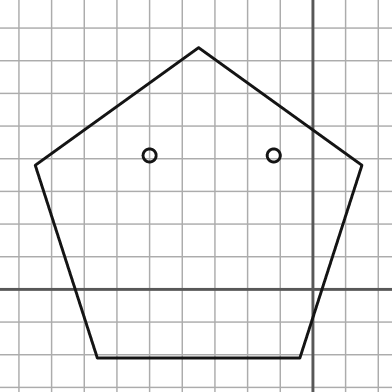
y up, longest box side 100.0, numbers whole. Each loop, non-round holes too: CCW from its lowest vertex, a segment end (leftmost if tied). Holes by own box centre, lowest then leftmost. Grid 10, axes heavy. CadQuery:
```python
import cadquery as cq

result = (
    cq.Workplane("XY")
    .moveTo(-66.0, -21.0)
    .lineTo(-4.0, -21.0)
    .lineTo(15.0, 38.0)
    .lineTo(-35.0, 74.0)
    .lineTo(-85.0, 38.0)
    .close()
    .moveTo(-50.0, 41.0)
    .circle(2.0)
    .moveTo(-12.0, 41.0)
    .circle(2.0)
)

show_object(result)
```